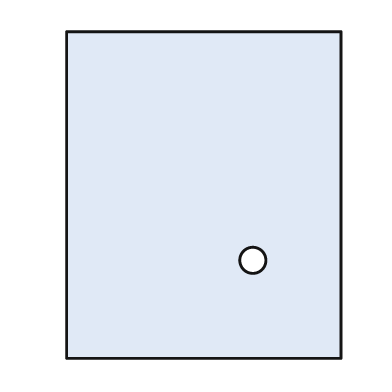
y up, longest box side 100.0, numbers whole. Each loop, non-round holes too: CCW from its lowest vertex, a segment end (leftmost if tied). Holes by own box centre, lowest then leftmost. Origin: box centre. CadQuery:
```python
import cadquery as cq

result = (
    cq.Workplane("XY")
    .moveTo(-42.0, -50.0)
    .lineTo(42.0, -50.0)
    .lineTo(42.0, 50.0)
    .lineTo(-42.0, 50.0)
    .close()
    .moveTo(15.0, -20.0)
    .circle(4.0)
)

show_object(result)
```